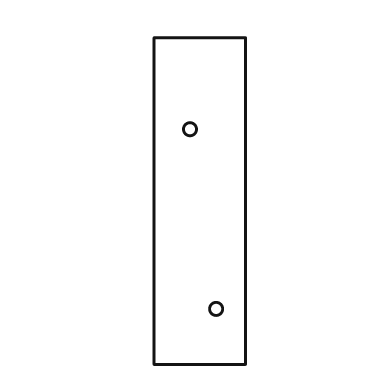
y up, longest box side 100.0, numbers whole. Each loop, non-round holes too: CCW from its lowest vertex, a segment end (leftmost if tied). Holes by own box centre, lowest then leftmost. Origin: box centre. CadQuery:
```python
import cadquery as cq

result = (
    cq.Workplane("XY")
    .moveTo(-14.0, -50.0)
    .lineTo(14.0, -50.0)
    .lineTo(14.0, 50.0)
    .lineTo(-14.0, 50.0)
    .close()
    .moveTo(5.0, -33.0)
    .circle(2.0)
    .moveTo(-3.0, 22.0)
    .circle(2.0)
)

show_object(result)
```